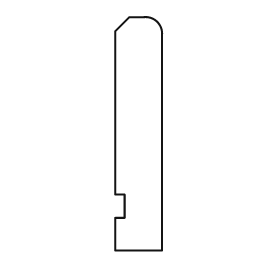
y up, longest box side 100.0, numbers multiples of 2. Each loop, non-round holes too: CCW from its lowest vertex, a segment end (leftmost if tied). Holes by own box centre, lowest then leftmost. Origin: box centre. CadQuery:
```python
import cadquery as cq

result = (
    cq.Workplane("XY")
    .moveTo(-10.0, -50.0)
    .lineTo(10.0, -50.0)
    .lineTo(10.0, 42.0)
    .threePointArc((8.0, 48.0), (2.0, 50.0))
    .lineTo(-4.0, 50.0)
    .lineTo(-10.0, 44.0)
    .lineTo(-10.0, -26.0)
    .lineTo(-6.0, -26.0)
    .lineTo(-6.0, -36.0)
    .lineTo(-10.0, -36.0)
    .close()
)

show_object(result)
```